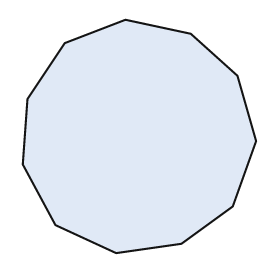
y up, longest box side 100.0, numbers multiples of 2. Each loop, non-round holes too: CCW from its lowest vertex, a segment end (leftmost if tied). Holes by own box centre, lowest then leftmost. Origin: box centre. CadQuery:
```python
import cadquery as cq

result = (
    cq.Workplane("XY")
    .moveTo(-10.0, -50.0)
    .lineTo(18.0, -46.0)
    .lineTo(40.0, -30.0)
    .lineTo(50.0, -2.0)
    .lineTo(42.0, 26.0)
    .lineTo(22.0, 44.0)
    .lineTo(-6.0, 50.0)
    .lineTo(-32.0, 40.0)
    .lineTo(-48.0, 16.0)
    .lineTo(-50.0, -12.0)
    .lineTo(-36.0, -38.0)
    .close()
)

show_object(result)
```